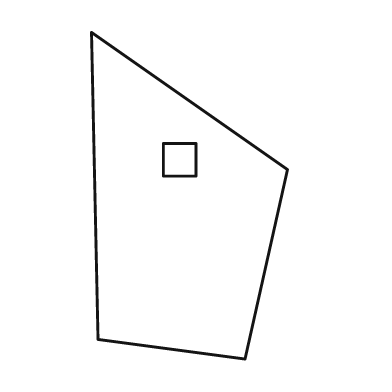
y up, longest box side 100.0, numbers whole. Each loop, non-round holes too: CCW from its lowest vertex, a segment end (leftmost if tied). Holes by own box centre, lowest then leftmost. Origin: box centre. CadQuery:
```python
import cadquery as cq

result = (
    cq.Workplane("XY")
    .moveTo(17.0, -50.0)
    .lineTo(30.0, 8.0)
    .lineTo(-30.0, 50.0)
    .lineTo(-28.0, -44.0)
    .close()
    .moveTo(-8.0, 6.0)
    .lineTo(2.0, 6.0)
    .lineTo(2.0, 16.0)
    .lineTo(-8.0, 16.0)
    .close()
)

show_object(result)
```